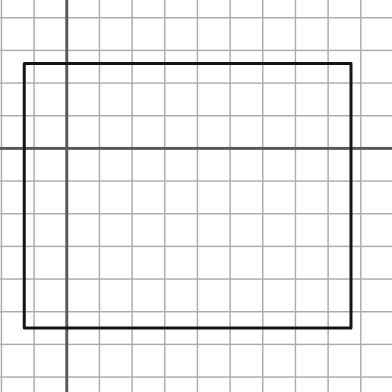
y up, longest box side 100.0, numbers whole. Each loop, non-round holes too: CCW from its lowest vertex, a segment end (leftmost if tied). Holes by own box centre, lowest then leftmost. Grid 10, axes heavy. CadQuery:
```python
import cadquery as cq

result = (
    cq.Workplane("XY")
    .moveTo(-13.0, -55.0)
    .lineTo(87.0, -55.0)
    .lineTo(87.0, 26.0)
    .lineTo(-13.0, 26.0)
    .close()
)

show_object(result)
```